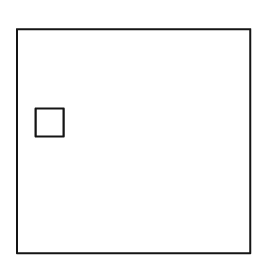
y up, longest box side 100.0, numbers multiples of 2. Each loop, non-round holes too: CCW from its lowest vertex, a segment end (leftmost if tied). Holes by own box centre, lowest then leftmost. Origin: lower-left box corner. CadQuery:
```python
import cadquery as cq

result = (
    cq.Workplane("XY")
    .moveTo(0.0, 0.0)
    .lineTo(100.0, 0.0)
    .lineTo(100.0, 96.0)
    .lineTo(0.0, 96.0)
    .close()
    .moveTo(8.0, 50.0)
    .lineTo(20.0, 50.0)
    .lineTo(20.0, 62.0)
    .lineTo(8.0, 62.0)
    .close()
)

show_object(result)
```